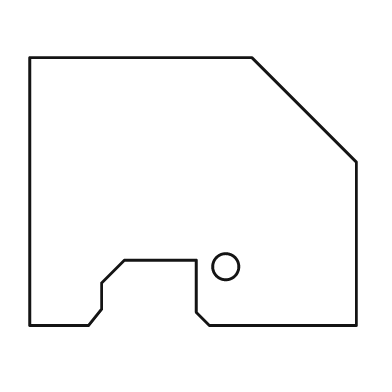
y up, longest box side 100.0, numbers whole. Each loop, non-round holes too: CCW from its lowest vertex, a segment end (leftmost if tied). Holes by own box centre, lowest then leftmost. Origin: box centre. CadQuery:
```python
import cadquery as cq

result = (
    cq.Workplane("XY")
    .moveTo(-50.0, -41.0)
    .lineTo(-32.0, -41.0)
    .lineTo(-28.0, -36.0)
    .lineTo(-28.0, -28.0)
    .lineTo(-21.0, -21.0)
    .lineTo(1.0, -21.0)
    .lineTo(1.0, -37.0)
    .lineTo(5.0, -41.0)
    .lineTo(50.0, -41.0)
    .lineTo(50.0, 9.0)
    .lineTo(18.0, 41.0)
    .lineTo(-50.0, 41.0)
    .close()
    .moveTo(10.0, -23.0)
    .circle(4.0)
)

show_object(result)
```